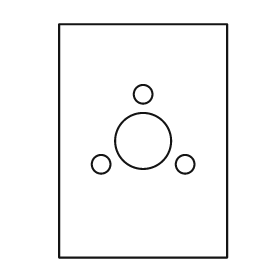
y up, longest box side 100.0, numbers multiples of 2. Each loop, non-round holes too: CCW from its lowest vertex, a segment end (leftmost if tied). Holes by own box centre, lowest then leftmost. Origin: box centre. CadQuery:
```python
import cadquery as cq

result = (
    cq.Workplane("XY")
    .moveTo(-36.0, -50.0)
    .lineTo(36.0, -50.0)
    .lineTo(36.0, 50.0)
    .lineTo(-36.0, 50.0)
    .close()
    .moveTo(-18.0, -10.0)
    .circle(4.0)
    .moveTo(18.0, -10.0)
    .circle(4.0)
    .moveTo(0.0, 0.0)
    .circle(12.0)
    .moveTo(0.0, 20.0)
    .circle(4.0)
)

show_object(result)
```